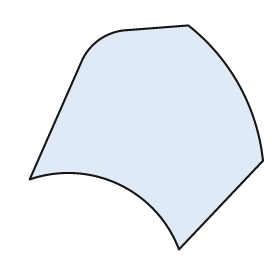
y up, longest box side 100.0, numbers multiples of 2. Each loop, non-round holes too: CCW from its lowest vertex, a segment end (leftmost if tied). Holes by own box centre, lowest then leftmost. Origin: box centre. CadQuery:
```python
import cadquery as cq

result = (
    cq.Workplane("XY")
    .moveTo(14.0, -48.0)
    .lineTo(50.0, -10.0)
    .threePointArc((40.0, 22.0), (18.0, 48.0))
    .lineTo(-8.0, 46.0)
    .threePointArc((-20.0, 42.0), (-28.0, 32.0))
    .lineTo(-50.0, -18.0)
    .threePointArc((-12.0, -20.0), (14.0, -48.0))
    .close()
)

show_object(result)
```